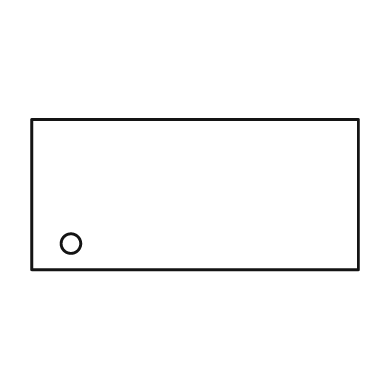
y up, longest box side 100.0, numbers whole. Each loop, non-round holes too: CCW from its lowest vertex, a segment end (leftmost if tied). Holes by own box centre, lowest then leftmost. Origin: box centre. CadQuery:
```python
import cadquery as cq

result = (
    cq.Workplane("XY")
    .moveTo(-50.0, -23.0)
    .lineTo(50.0, -23.0)
    .lineTo(50.0, 23.0)
    .lineTo(-50.0, 23.0)
    .close()
    .moveTo(-38.0, -15.0)
    .circle(3.0)
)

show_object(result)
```